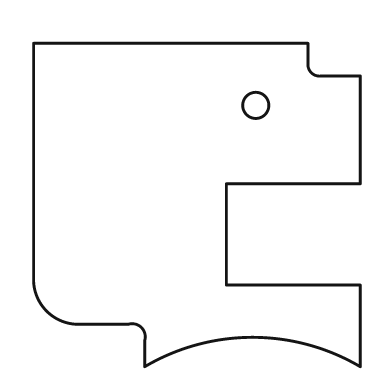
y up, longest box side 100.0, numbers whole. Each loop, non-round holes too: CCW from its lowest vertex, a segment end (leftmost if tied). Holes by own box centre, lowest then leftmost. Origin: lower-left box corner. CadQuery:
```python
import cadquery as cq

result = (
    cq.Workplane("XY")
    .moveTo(34.0, 0.0)
    .threePointArc((67.0, 9.0), (100.0, 0.0))
    .lineTo(100.0, 25.0)
    .lineTo(59.0, 25.0)
    .lineTo(59.0, 56.0)
    .lineTo(100.0, 56.0)
    .lineTo(100.0, 89.0)
    .lineTo(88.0, 89.0)
    .threePointArc((85.0, 90.0), (84.0, 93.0))
    .lineTo(84.0, 99.0)
    .lineTo(0.0, 99.0)
    .lineTo(0.0, 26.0)
    .threePointArc((4.0, 17.0), (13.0, 13.0))
    .lineTo(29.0, 13.0)
    .threePointArc((33.0, 12.0), (34.0, 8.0))
    .close()
    .moveTo(68.0, 80.0)
    .circle(4.0)
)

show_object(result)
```